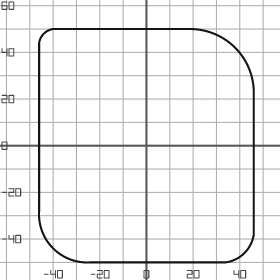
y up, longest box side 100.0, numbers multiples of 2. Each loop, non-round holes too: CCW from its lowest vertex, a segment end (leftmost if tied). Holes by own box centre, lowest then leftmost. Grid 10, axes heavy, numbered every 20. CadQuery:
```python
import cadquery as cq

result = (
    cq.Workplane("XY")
    .moveTo(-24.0, -50.0)
    .lineTo(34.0, -50.0)
    .threePointArc((42.0, -46.0), (46.0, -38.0))
    .lineTo(46.0, 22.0)
    .threePointArc((38.0, 42.0), (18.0, 50.0))
    .lineTo(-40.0, 50.0)
    .threePointArc((-44.0, 48.0), (-46.0, 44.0))
    .lineTo(-46.0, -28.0)
    .threePointArc((-40.0, -44.0), (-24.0, -50.0))
    .close()
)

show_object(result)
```